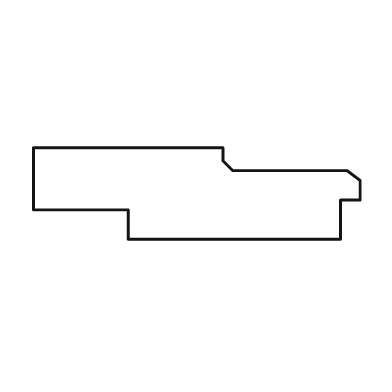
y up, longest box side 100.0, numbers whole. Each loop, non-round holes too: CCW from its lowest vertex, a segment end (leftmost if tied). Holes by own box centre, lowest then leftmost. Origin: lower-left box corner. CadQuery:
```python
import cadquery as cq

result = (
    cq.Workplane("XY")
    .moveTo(29.0, 0.0)
    .lineTo(94.0, 0.0)
    .lineTo(94.0, 12.0)
    .lineTo(100.0, 12.0)
    .lineTo(100.0, 18.0)
    .lineTo(96.0, 21.0)
    .lineTo(61.0, 21.0)
    .lineTo(58.0, 24.0)
    .lineTo(58.0, 28.0)
    .lineTo(0.0, 28.0)
    .lineTo(0.0, 9.0)
    .lineTo(29.0, 9.0)
    .close()
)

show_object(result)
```